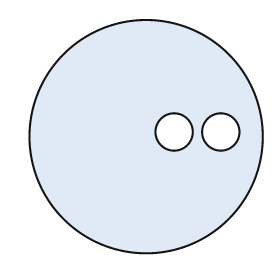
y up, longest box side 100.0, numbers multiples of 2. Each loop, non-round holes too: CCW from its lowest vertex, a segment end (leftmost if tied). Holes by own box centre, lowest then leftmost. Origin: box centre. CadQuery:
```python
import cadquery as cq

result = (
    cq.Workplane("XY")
    .moveTo(0.0, 0.0)
    .circle(50.0)
    .moveTo(12.0, 2.0)
    .circle(8.0)
    .moveTo(32.0, 2.0)
    .circle(8.0)
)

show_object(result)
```